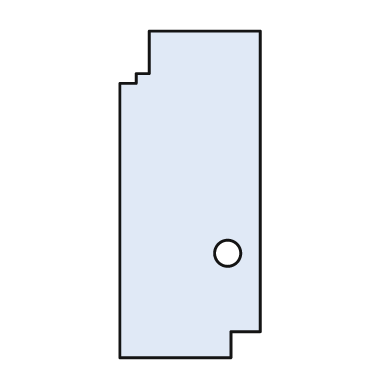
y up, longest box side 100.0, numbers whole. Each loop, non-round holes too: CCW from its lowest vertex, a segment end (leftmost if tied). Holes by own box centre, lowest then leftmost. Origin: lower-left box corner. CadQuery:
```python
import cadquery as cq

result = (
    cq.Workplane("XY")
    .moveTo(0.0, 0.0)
    .lineTo(34.0, 0.0)
    .lineTo(34.0, 8.0)
    .lineTo(43.0, 8.0)
    .lineTo(43.0, 100.0)
    .lineTo(9.0, 100.0)
    .lineTo(9.0, 87.0)
    .lineTo(5.0, 87.0)
    .lineTo(5.0, 84.0)
    .lineTo(0.0, 84.0)
    .close()
    .moveTo(33.0, 32.0)
    .circle(4.0)
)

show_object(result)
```